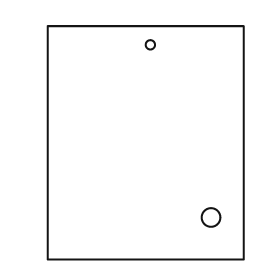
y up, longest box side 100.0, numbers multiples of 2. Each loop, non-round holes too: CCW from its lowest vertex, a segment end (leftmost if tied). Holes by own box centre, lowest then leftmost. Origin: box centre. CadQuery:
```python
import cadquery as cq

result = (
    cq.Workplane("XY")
    .moveTo(-42.0, -50.0)
    .lineTo(42.0, -50.0)
    .lineTo(42.0, 50.0)
    .lineTo(-42.0, 50.0)
    .close()
    .moveTo(28.0, -32.0)
    .circle(4.0)
    .moveTo(2.0, 42.0)
    .circle(2.0)
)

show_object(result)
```